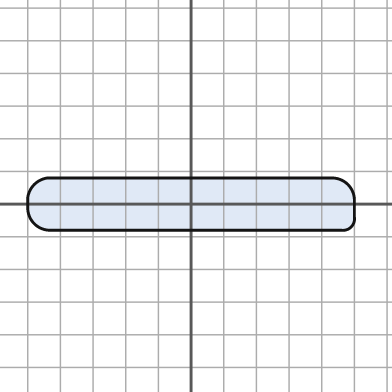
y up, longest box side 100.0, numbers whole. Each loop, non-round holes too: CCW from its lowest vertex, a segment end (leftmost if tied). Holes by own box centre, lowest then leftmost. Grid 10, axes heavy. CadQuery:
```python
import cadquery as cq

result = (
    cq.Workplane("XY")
    .moveTo(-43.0, -8.0)
    .lineTo(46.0, -8.0)
    .threePointArc((49.0, -7.0), (50.0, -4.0))
    .lineTo(50.0, 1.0)
    .threePointArc((48.0, 6.0), (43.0, 8.0))
    .lineTo(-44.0, 8.0)
    .threePointArc((-48.0, 6.0), (-50.0, 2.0))
    .lineTo(-50.0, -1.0)
    .threePointArc((-48.0, -6.0), (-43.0, -8.0))
    .close()
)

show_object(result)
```